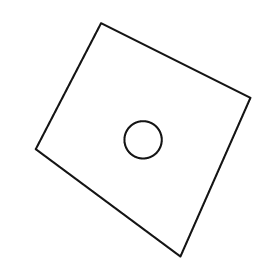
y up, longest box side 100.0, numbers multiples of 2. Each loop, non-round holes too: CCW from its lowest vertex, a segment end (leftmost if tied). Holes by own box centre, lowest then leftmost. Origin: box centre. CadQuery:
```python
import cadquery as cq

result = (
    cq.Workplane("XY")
    .moveTo(16.0, -50.0)
    .lineTo(46.0, 18.0)
    .lineTo(-18.0, 50.0)
    .lineTo(-46.0, -4.0)
    .close()
    .moveTo(0.0, 0.0)
    .circle(8.0)
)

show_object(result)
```